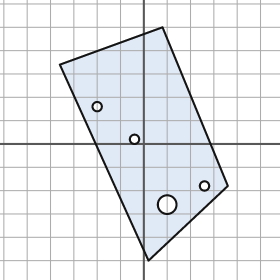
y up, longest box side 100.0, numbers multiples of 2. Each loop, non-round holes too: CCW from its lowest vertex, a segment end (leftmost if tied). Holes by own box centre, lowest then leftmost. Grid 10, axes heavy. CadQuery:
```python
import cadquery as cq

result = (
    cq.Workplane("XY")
    .moveTo(2.0, -50.0)
    .lineTo(36.0, -18.0)
    .lineTo(8.0, 50.0)
    .lineTo(-36.0, 34.0)
    .close()
    .moveTo(10.0, -26.0)
    .circle(4.0)
    .moveTo(26.0, -18.0)
    .circle(2.0)
    .moveTo(-4.0, 2.0)
    .circle(2.0)
    .moveTo(-20.0, 16.0)
    .circle(2.0)
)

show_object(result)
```